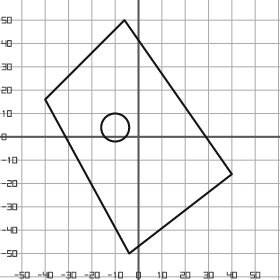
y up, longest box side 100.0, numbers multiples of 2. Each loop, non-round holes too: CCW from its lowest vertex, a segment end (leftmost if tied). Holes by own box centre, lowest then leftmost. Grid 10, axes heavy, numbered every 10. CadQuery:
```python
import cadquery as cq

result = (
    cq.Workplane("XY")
    .moveTo(-4.0, -50.0)
    .lineTo(40.0, -16.0)
    .lineTo(-6.0, 50.0)
    .lineTo(-40.0, 16.0)
    .close()
    .moveTo(-10.0, 4.0)
    .circle(6.0)
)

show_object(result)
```